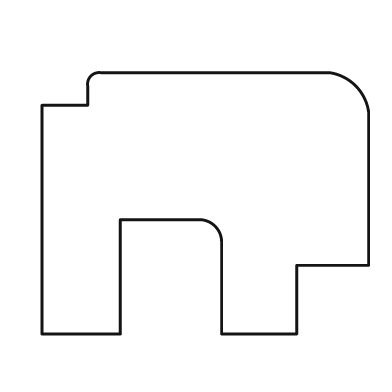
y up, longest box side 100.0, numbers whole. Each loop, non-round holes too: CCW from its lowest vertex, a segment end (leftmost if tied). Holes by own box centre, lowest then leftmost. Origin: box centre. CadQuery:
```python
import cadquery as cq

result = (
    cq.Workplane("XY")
    .moveTo(-50.0, -40.0)
    .lineTo(-26.0, -40.0)
    .lineTo(-26.0, -5.0)
    .lineTo(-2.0, -5.0)
    .threePointArc((3.0, -7.0), (5.0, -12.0))
    .lineTo(5.0, -40.0)
    .lineTo(28.0, -40.0)
    .lineTo(28.0, -19.0)
    .lineTo(50.0, -19.0)
    .lineTo(50.0, 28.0)
    .threePointArc((46.0, 36.0), (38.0, 40.0))
    .lineTo(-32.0, 40.0)
    .threePointArc((-35.0, 39.0), (-36.0, 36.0))
    .lineTo(-36.0, 30.0)
    .lineTo(-50.0, 30.0)
    .close()
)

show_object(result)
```